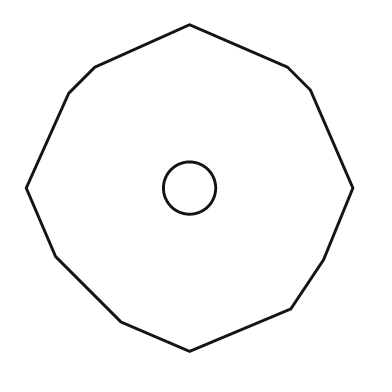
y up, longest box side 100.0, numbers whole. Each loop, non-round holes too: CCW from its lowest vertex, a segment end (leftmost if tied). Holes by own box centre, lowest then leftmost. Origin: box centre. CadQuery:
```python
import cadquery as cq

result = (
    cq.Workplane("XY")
    .moveTo(0.0, -50.0)
    .lineTo(31.0, -37.0)
    .lineTo(41.0, -22.0)
    .lineTo(50.0, 0.0)
    .lineTo(37.0, 30.0)
    .lineTo(30.0, 37.0)
    .lineTo(0.0, 50.0)
    .lineTo(-29.0, 37.0)
    .lineTo(-37.0, 29.0)
    .lineTo(-50.0, 0.0)
    .lineTo(-41.0, -21.0)
    .lineTo(-21.0, -41.0)
    .close()
    .moveTo(0.0, 0.0)
    .circle(8.0)
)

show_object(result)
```